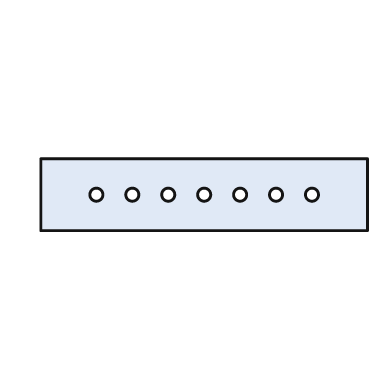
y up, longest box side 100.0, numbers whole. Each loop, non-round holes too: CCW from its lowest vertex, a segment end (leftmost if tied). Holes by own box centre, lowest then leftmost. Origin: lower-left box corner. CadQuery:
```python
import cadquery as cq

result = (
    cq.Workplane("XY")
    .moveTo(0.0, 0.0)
    .lineTo(100.0, 0.0)
    .lineTo(100.0, 22.0)
    .lineTo(0.0, 22.0)
    .close()
    .moveTo(17.0, 11.0)
    .circle(2.0)
    .moveTo(28.0, 11.0)
    .circle(2.0)
    .moveTo(39.0, 11.0)
    .circle(2.0)
    .moveTo(50.0, 11.0)
    .circle(2.0)
    .moveTo(61.0, 11.0)
    .circle(2.0)
    .moveTo(72.0, 11.0)
    .circle(2.0)
    .moveTo(83.0, 11.0)
    .circle(2.0)
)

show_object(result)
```